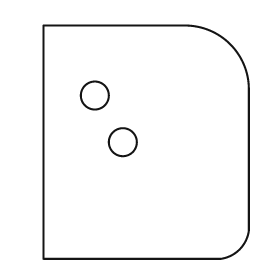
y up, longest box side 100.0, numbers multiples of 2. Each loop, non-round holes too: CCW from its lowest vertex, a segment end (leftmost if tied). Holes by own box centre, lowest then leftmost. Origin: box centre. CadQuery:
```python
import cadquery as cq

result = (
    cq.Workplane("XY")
    .moveTo(-44.0, -50.0)
    .lineTo(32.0, -50.0)
    .threePointArc((40.0, -46.0), (44.0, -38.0))
    .lineTo(44.0, 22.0)
    .threePointArc((36.0, 42.0), (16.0, 50.0))
    .lineTo(-44.0, 50.0)
    .close()
    .moveTo(-10.0, 0.0)
    .circle(6.0)
    .moveTo(-22.0, 20.0)
    .circle(6.0)
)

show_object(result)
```